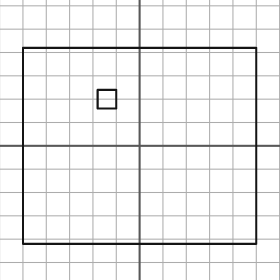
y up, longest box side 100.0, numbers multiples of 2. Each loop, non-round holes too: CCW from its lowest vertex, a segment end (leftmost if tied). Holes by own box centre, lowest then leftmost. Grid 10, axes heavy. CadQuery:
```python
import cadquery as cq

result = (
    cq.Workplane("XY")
    .moveTo(-50.0, -42.0)
    .lineTo(50.0, -42.0)
    .lineTo(50.0, 42.0)
    .lineTo(-50.0, 42.0)
    .close()
    .moveTo(-18.0, 16.0)
    .lineTo(-10.0, 16.0)
    .lineTo(-10.0, 24.0)
    .lineTo(-18.0, 24.0)
    .close()
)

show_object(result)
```